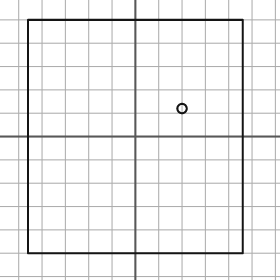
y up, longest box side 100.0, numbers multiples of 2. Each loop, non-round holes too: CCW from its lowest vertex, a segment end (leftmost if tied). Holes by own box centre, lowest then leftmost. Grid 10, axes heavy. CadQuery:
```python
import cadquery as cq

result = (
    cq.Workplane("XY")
    .moveTo(-46.0, -50.0)
    .lineTo(46.0, -50.0)
    .lineTo(46.0, 50.0)
    .lineTo(-46.0, 50.0)
    .close()
    .moveTo(20.0, 12.0)
    .circle(2.0)
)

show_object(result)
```